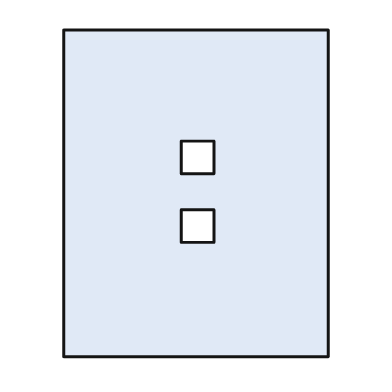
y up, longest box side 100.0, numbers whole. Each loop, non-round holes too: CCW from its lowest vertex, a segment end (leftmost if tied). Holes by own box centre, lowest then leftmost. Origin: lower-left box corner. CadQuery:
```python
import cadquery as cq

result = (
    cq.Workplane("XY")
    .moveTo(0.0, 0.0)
    .lineTo(81.0, 0.0)
    .lineTo(81.0, 100.0)
    .lineTo(0.0, 100.0)
    .close()
    .moveTo(36.0, 35.0)
    .lineTo(46.0, 35.0)
    .lineTo(46.0, 45.0)
    .lineTo(36.0, 45.0)
    .close()
    .moveTo(36.0, 56.0)
    .lineTo(46.0, 56.0)
    .lineTo(46.0, 66.0)
    .lineTo(36.0, 66.0)
    .close()
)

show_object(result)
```